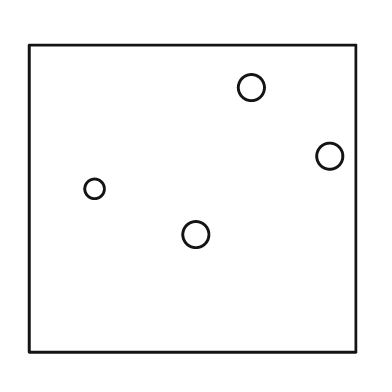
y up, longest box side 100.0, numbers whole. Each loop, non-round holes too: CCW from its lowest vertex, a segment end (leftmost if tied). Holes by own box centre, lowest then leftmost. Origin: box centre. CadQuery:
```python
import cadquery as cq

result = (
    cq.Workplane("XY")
    .moveTo(-50.0, -47.0)
    .lineTo(50.0, -47.0)
    .lineTo(50.0, 47.0)
    .lineTo(-50.0, 47.0)
    .close()
    .moveTo(1.0, -11.0)
    .circle(4.0)
    .moveTo(-30.0, 3.0)
    .circle(3.0)
    .moveTo(42.0, 13.0)
    .circle(4.0)
    .moveTo(18.0, 34.0)
    .circle(4.0)
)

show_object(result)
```